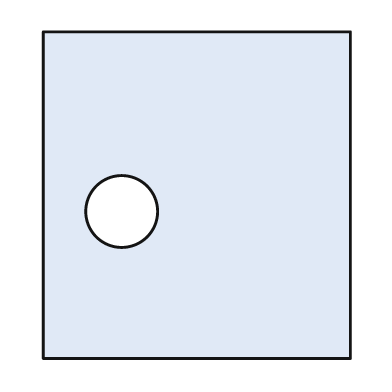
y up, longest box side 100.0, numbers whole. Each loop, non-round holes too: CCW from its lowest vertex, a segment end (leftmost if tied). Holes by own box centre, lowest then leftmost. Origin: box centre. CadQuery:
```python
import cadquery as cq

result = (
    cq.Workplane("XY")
    .moveTo(-47.0, -50.0)
    .lineTo(47.0, -50.0)
    .lineTo(47.0, 50.0)
    .lineTo(-47.0, 50.0)
    .close()
    .moveTo(-23.0, -5.0)
    .circle(11.0)
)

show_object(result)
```